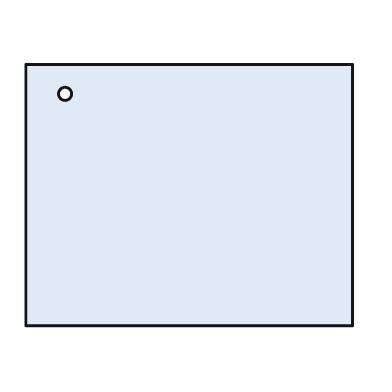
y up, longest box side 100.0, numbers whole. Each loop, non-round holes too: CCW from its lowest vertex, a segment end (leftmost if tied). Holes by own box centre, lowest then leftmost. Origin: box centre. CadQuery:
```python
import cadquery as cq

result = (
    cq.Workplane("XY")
    .moveTo(-50.0, -40.0)
    .lineTo(50.0, -40.0)
    .lineTo(50.0, 40.0)
    .lineTo(-50.0, 40.0)
    .close()
    .moveTo(-38.0, 31.0)
    .circle(2.0)
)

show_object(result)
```